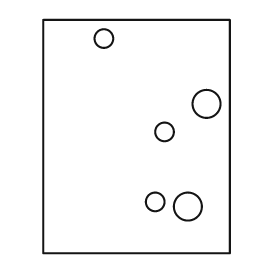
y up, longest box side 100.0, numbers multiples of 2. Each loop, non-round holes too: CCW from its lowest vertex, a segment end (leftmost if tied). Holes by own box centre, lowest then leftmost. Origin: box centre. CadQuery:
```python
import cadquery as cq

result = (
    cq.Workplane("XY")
    .moveTo(-40.0, -50.0)
    .lineTo(40.0, -50.0)
    .lineTo(40.0, 50.0)
    .lineTo(-40.0, 50.0)
    .close()
    .moveTo(22.0, -30.0)
    .circle(6.0)
    .moveTo(8.0, -28.0)
    .circle(4.0)
    .moveTo(12.0, 2.0)
    .circle(4.0)
    .moveTo(30.0, 14.0)
    .circle(6.0)
    .moveTo(-14.0, 42.0)
    .circle(4.0)
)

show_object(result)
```